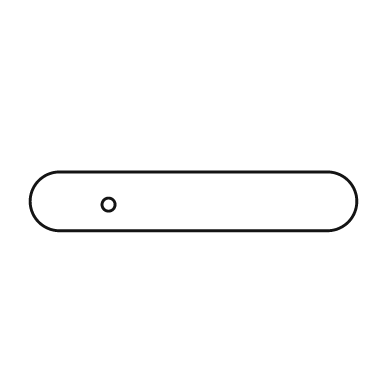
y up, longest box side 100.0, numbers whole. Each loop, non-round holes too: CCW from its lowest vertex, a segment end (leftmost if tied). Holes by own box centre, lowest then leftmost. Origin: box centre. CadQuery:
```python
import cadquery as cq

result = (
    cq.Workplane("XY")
    .moveTo(-41.0, -9.0)
    .lineTo(41.0, -9.0)
    .threePointArc((50.0, 0.0), (41.0, 9.0))
    .lineTo(-41.0, 9.0)
    .threePointArc((-50.0, 0.0), (-41.0, -9.0))
    .close()
    .moveTo(-26.0, -1.0)
    .circle(2.0)
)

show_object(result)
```